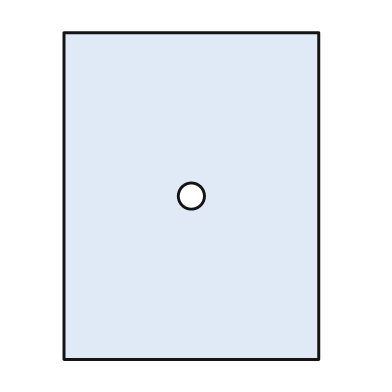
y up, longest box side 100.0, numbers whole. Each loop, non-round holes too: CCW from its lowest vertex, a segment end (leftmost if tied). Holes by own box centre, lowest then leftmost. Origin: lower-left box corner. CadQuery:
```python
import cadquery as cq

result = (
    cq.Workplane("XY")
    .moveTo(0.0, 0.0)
    .lineTo(78.0, 0.0)
    .lineTo(78.0, 100.0)
    .lineTo(0.0, 100.0)
    .close()
    .moveTo(39.0, 50.0)
    .circle(4.0)
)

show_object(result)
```